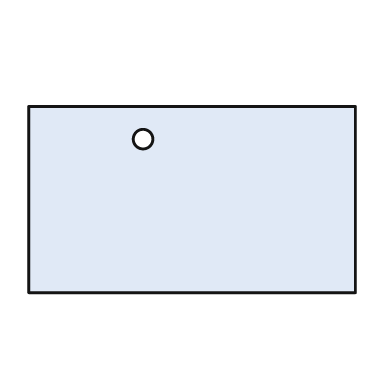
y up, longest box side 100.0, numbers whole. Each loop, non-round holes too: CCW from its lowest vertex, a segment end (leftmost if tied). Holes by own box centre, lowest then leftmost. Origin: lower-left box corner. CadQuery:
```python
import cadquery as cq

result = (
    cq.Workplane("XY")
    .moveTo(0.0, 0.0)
    .lineTo(100.0, 0.0)
    .lineTo(100.0, 57.0)
    .lineTo(0.0, 57.0)
    .close()
    .moveTo(35.0, 47.0)
    .circle(3.0)
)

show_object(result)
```